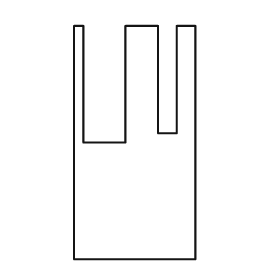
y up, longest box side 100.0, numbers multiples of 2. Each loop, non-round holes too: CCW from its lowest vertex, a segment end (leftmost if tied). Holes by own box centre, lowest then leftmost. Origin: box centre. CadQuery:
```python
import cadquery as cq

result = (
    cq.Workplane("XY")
    .moveTo(-26.0, -50.0)
    .lineTo(26.0, -50.0)
    .lineTo(26.0, 50.0)
    .lineTo(18.0, 50.0)
    .lineTo(18.0, 4.0)
    .lineTo(10.0, 4.0)
    .lineTo(10.0, 50.0)
    .lineTo(-4.0, 50.0)
    .lineTo(-4.0, 0.0)
    .lineTo(-22.0, 0.0)
    .lineTo(-22.0, 50.0)
    .lineTo(-26.0, 50.0)
    .close()
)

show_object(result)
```